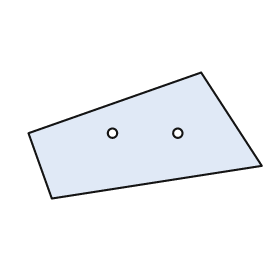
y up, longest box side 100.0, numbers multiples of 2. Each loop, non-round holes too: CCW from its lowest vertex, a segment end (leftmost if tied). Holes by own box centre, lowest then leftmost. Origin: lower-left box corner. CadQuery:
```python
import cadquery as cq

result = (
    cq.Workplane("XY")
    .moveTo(10.0, 0.0)
    .lineTo(100.0, 14.0)
    .lineTo(74.0, 54.0)
    .lineTo(0.0, 28.0)
    .close()
    .moveTo(36.0, 28.0)
    .circle(2.0)
    .moveTo(64.0, 28.0)
    .circle(2.0)
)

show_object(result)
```